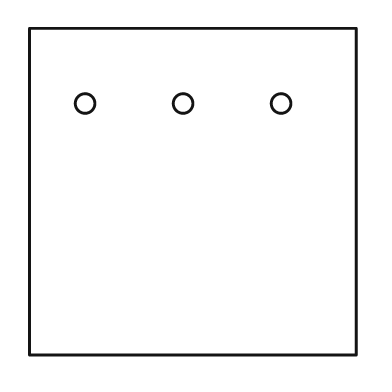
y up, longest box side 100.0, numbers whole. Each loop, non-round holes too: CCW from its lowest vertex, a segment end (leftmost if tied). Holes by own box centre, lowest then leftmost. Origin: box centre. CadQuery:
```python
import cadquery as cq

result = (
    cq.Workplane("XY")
    .moveTo(-50.0, -50.0)
    .lineTo(50.0, -50.0)
    .lineTo(50.0, 50.0)
    .lineTo(-50.0, 50.0)
    .close()
    .moveTo(-33.0, 27.0)
    .circle(3.0)
    .moveTo(-3.0, 27.0)
    .circle(3.0)
    .moveTo(27.0, 27.0)
    .circle(3.0)
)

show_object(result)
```